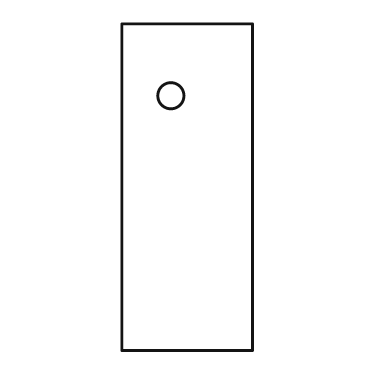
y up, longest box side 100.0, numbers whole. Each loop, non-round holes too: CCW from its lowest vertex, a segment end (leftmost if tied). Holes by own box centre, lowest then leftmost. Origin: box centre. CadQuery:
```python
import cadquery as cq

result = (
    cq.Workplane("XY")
    .moveTo(-20.0, -50.0)
    .lineTo(20.0, -50.0)
    .lineTo(20.0, 50.0)
    .lineTo(-20.0, 50.0)
    .close()
    .moveTo(-5.0, 28.0)
    .circle(4.0)
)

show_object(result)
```